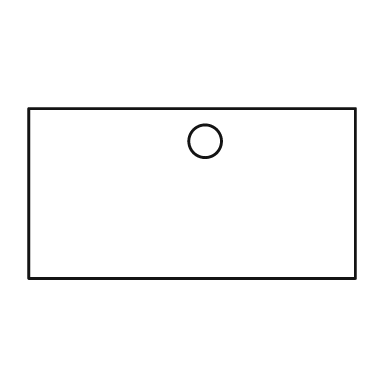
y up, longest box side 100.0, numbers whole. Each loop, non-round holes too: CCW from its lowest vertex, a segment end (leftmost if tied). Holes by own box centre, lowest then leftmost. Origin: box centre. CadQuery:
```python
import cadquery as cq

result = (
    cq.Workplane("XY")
    .moveTo(-50.0, -26.0)
    .lineTo(50.0, -26.0)
    .lineTo(50.0, 26.0)
    .lineTo(-50.0, 26.0)
    .close()
    .moveTo(4.0, 16.0)
    .circle(5.0)
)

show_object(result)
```